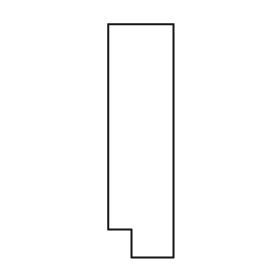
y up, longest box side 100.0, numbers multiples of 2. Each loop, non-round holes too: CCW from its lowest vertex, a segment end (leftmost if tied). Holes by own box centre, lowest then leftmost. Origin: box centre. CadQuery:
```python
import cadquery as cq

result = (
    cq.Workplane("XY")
    .moveTo(-4.0, -50.0)
    .lineTo(14.0, -50.0)
    .lineTo(14.0, 50.0)
    .lineTo(-14.0, 50.0)
    .lineTo(-14.0, -38.0)
    .lineTo(-4.0, -38.0)
    .close()
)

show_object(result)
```